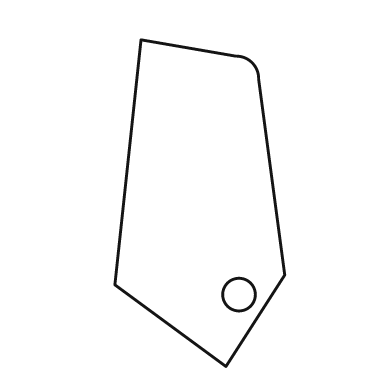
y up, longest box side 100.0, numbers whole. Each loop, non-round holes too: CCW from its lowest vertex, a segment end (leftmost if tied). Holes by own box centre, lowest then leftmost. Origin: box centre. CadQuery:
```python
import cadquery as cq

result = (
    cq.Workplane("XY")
    .moveTo(8.0, -50.0)
    .lineTo(26.0, -22.0)
    .lineTo(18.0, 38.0)
    .threePointArc((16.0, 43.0), (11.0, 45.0))
    .lineTo(-18.0, 50.0)
    .lineTo(-26.0, -25.0)
    .close()
    .moveTo(12.0, -28.0)
    .circle(5.0)
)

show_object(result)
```